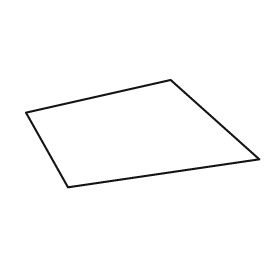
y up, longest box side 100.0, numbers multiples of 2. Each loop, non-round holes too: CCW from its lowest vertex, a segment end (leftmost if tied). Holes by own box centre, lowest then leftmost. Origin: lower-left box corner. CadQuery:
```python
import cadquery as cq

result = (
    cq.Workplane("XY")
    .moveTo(18.0, 0.0)
    .lineTo(100.0, 12.0)
    .lineTo(62.0, 46.0)
    .lineTo(0.0, 32.0)
    .close()
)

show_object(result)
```